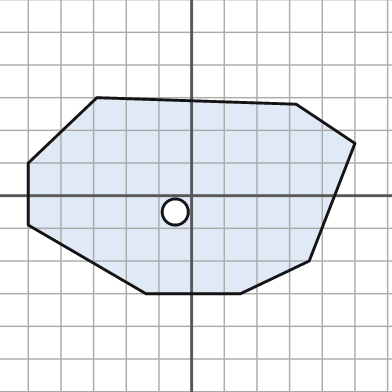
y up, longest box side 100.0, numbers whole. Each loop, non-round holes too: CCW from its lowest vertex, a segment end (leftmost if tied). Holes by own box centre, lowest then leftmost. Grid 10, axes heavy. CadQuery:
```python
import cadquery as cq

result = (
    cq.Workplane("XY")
    .moveTo(-14.0, -30.0)
    .lineTo(15.0, -30.0)
    .lineTo(36.0, -20.0)
    .lineTo(50.0, 16.0)
    .lineTo(32.0, 28.0)
    .lineTo(-29.0, 30.0)
    .lineTo(-50.0, 10.0)
    .lineTo(-50.0, -9.0)
    .close()
    .moveTo(-5.0, -5.0)
    .circle(4.0)
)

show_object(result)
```